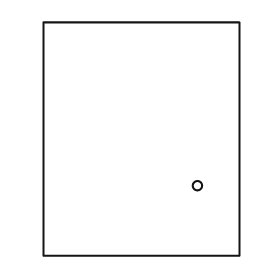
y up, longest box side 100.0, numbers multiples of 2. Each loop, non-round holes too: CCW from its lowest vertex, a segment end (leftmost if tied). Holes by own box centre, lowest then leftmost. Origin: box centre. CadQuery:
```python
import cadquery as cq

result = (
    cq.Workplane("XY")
    .moveTo(-42.0, -50.0)
    .lineTo(42.0, -50.0)
    .lineTo(42.0, 50.0)
    .lineTo(-42.0, 50.0)
    .close()
    .moveTo(24.0, -20.0)
    .circle(2.0)
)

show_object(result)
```